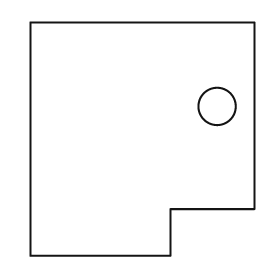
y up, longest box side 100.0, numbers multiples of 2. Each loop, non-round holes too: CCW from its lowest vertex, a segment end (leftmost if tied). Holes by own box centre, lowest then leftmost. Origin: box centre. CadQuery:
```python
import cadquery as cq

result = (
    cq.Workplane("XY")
    .moveTo(-48.0, -50.0)
    .lineTo(12.0, -50.0)
    .lineTo(12.0, -30.0)
    .lineTo(48.0, -30.0)
    .lineTo(48.0, 50.0)
    .lineTo(-48.0, 50.0)
    .close()
    .moveTo(32.0, 14.0)
    .circle(8.0)
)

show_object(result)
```